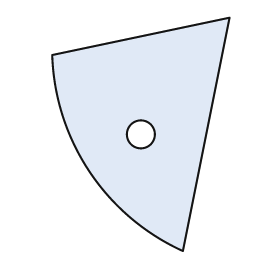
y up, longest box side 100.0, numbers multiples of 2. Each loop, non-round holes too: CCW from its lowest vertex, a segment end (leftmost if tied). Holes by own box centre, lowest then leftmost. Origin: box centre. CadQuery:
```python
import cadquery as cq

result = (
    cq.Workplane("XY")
    .moveTo(18.0, -50.0)
    .lineTo(38.0, 50.0)
    .lineTo(-38.0, 34.0)
    .threePointArc((-22.0, -16.0), (18.0, -50.0))
    .close()
    .moveTo(0.0, 0.0)
    .circle(6.0)
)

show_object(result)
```